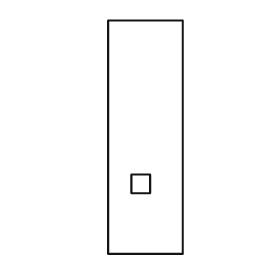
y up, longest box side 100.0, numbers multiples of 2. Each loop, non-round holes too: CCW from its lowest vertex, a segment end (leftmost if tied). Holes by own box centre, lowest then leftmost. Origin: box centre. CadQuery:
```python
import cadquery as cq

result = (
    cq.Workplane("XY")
    .moveTo(-16.0, -50.0)
    .lineTo(16.0, -50.0)
    .lineTo(16.0, 50.0)
    .lineTo(-16.0, 50.0)
    .close()
    .moveTo(-6.0, -24.0)
    .lineTo(2.0, -24.0)
    .lineTo(2.0, -16.0)
    .lineTo(-6.0, -16.0)
    .close()
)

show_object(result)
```